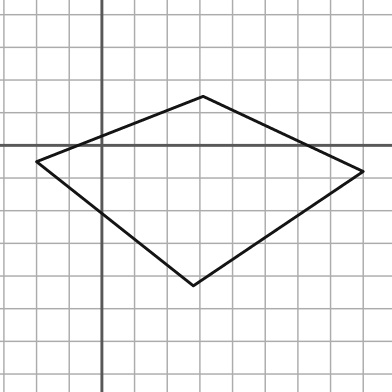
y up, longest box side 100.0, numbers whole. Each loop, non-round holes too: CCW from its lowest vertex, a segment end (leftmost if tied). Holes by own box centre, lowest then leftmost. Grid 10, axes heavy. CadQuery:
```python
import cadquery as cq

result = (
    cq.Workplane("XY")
    .moveTo(28.0, -43.0)
    .lineTo(80.0, -8.0)
    .lineTo(31.0, 15.0)
    .lineTo(-20.0, -5.0)
    .close()
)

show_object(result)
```